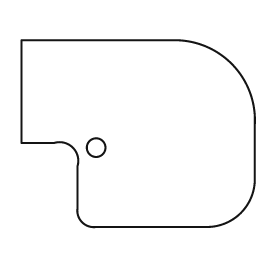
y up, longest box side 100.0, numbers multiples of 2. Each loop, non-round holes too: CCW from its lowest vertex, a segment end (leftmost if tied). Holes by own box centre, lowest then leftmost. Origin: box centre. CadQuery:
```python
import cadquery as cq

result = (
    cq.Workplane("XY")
    .moveTo(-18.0, -40.0)
    .lineTo(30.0, -40.0)
    .threePointArc((44.0, -34.0), (50.0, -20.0))
    .lineTo(50.0, 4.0)
    .threePointArc((40.0, 30.0), (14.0, 40.0))
    .lineTo(-50.0, 40.0)
    .lineTo(-50.0, -4.0)
    .lineTo(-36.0, -4.0)
    .threePointArc((-28.0, -6.0), (-26.0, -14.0))
    .lineTo(-26.0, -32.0)
    .threePointArc((-24.0, -38.0), (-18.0, -40.0))
    .close()
    .moveTo(-18.0, -6.0)
    .circle(4.0)
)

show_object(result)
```